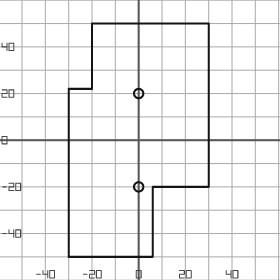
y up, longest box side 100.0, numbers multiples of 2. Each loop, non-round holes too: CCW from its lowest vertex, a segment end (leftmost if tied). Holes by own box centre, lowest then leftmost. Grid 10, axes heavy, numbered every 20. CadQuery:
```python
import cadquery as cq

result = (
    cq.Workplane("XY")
    .moveTo(-30.0, -50.0)
    .lineTo(6.0, -50.0)
    .lineTo(6.0, -20.0)
    .lineTo(30.0, -20.0)
    .lineTo(30.0, 50.0)
    .lineTo(-20.0, 50.0)
    .lineTo(-20.0, 22.0)
    .lineTo(-30.0, 22.0)
    .close()
    .moveTo(0.0, -20.0)
    .circle(2.0)
    .moveTo(0.0, 20.0)
    .circle(2.0)
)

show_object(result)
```